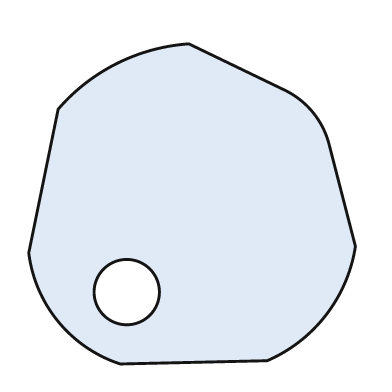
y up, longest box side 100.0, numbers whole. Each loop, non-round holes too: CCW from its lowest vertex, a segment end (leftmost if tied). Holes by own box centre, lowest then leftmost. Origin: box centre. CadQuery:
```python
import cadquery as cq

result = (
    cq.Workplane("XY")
    .moveTo(-22.0, -49.0)
    .lineTo(23.0, -48.0)
    .threePointArc((41.0, -34.0), (50.0, -13.0))
    .lineTo(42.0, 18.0)
    .threePointArc((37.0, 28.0), (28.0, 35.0))
    .lineTo(-1.0, 49.0)
    .threePointArc((-23.0, 43.0), (-41.0, 29.0))
    .lineTo(-50.0, -15.0)
    .threePointArc((-41.0, -36.0), (-22.0, -49.0))
    .close()
    .moveTo(-20.0, -27.0)
    .circle(10.0)
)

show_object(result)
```